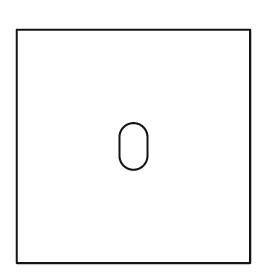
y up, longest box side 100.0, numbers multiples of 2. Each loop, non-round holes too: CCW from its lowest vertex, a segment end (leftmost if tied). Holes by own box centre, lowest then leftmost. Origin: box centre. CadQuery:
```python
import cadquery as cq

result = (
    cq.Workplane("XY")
    .moveTo(-50.0, -50.0)
    .lineTo(50.0, -50.0)
    .lineTo(50.0, 50.0)
    .lineTo(-50.0, 50.0)
    .close()
    .moveTo(-6.0, -4.0)
    .threePointArc((0.0, -10.0), (6.0, -4.0))
    .lineTo(6.0, 4.0)
    .threePointArc((0.0, 10.0), (-6.0, 4.0))
    .close()
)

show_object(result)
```